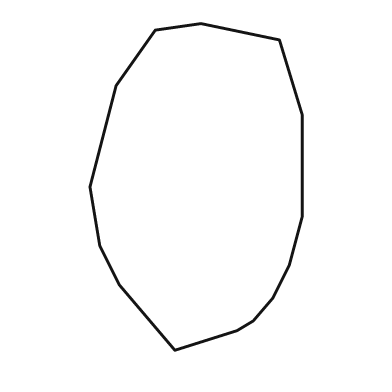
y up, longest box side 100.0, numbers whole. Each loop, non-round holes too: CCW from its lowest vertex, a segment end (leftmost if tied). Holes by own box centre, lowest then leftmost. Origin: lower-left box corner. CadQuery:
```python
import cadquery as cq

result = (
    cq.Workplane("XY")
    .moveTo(26.0, 0.0)
    .lineTo(45.0, 6.0)
    .lineTo(50.0, 9.0)
    .lineTo(56.0, 16.0)
    .lineTo(61.0, 26.0)
    .lineTo(65.0, 41.0)
    .lineTo(65.0, 72.0)
    .lineTo(58.0, 95.0)
    .lineTo(34.0, 100.0)
    .lineTo(20.0, 98.0)
    .lineTo(8.0, 81.0)
    .lineTo(0.0, 50.0)
    .lineTo(3.0, 32.0)
    .lineTo(9.0, 20.0)
    .close()
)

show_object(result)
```